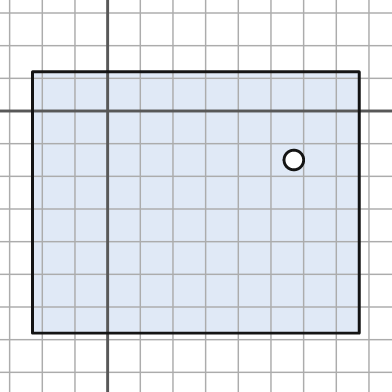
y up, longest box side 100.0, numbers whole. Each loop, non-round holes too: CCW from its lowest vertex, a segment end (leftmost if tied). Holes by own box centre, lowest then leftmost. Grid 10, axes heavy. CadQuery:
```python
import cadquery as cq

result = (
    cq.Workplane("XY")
    .moveTo(-23.0, -68.0)
    .lineTo(77.0, -68.0)
    .lineTo(77.0, 12.0)
    .lineTo(-23.0, 12.0)
    .close()
    .moveTo(57.0, -15.0)
    .circle(3.0)
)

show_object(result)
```